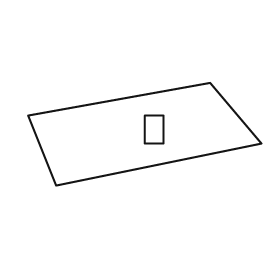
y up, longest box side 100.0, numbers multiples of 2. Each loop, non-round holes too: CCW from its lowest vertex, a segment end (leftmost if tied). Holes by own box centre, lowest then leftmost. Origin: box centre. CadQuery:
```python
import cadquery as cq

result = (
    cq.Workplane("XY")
    .moveTo(-38.0, -22.0)
    .lineTo(50.0, -4.0)
    .lineTo(28.0, 22.0)
    .lineTo(-50.0, 8.0)
    .close()
    .moveTo(0.0, -4.0)
    .lineTo(8.0, -4.0)
    .lineTo(8.0, 8.0)
    .lineTo(0.0, 8.0)
    .close()
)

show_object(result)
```